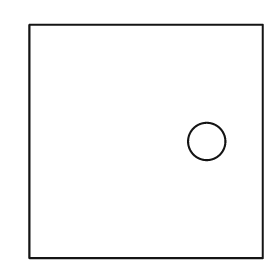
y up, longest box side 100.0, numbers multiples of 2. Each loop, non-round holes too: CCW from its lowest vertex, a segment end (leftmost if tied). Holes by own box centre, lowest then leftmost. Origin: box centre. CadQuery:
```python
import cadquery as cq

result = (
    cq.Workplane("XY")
    .moveTo(-50.0, -50.0)
    .lineTo(50.0, -50.0)
    .lineTo(50.0, 50.0)
    .lineTo(-50.0, 50.0)
    .close()
    .moveTo(26.0, 0.0)
    .circle(8.0)
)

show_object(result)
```